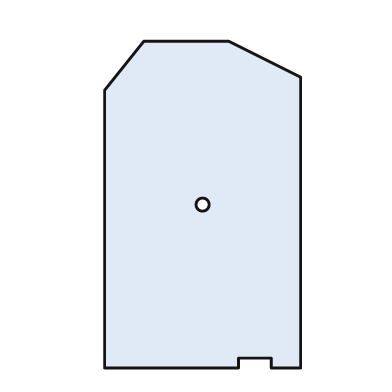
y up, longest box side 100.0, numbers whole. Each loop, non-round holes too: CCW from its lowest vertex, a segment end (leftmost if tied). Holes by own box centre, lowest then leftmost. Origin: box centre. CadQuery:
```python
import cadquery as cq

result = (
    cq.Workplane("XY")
    .moveTo(-30.0, -50.0)
    .lineTo(11.0, -50.0)
    .lineTo(11.0, -47.0)
    .lineTo(21.0, -47.0)
    .lineTo(21.0, -50.0)
    .lineTo(30.0, -50.0)
    .lineTo(30.0, 39.0)
    .lineTo(8.0, 50.0)
    .lineTo(-18.0, 50.0)
    .lineTo(-30.0, 35.0)
    .close()
    .moveTo(0.0, 0.0)
    .circle(2.0)
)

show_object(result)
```